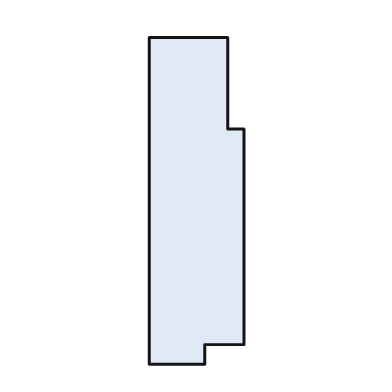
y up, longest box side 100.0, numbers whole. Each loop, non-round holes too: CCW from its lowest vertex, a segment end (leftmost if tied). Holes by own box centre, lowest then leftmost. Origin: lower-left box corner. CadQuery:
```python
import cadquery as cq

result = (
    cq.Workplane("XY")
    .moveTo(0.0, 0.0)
    .lineTo(17.0, 0.0)
    .lineTo(17.0, 6.0)
    .lineTo(29.0, 6.0)
    .lineTo(29.0, 72.0)
    .lineTo(24.0, 72.0)
    .lineTo(24.0, 100.0)
    .lineTo(0.0, 100.0)
    .close()
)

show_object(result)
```